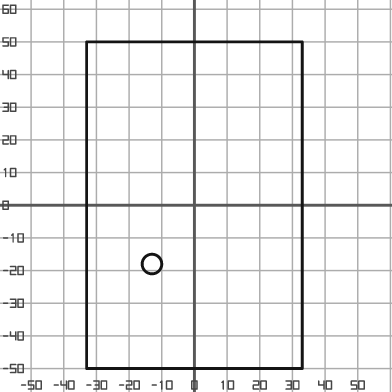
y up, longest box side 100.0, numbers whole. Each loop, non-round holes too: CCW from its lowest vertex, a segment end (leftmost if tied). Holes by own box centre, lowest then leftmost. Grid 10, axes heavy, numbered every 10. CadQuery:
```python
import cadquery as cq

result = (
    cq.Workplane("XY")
    .moveTo(-33.0, -50.0)
    .lineTo(33.0, -50.0)
    .lineTo(33.0, 50.0)
    .lineTo(-33.0, 50.0)
    .close()
    .moveTo(-13.0, -18.0)
    .circle(3.0)
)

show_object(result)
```